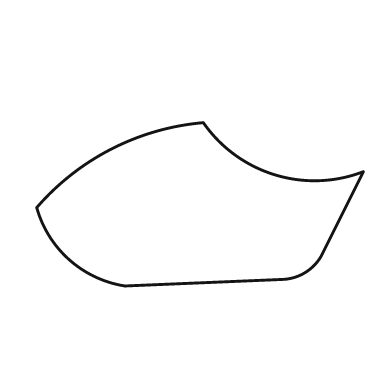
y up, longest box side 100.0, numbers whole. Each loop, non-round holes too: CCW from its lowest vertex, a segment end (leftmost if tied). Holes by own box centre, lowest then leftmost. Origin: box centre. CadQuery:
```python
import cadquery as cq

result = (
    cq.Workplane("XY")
    .moveTo(-23.0, -25.0)
    .lineTo(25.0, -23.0)
    .threePointArc((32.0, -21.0), (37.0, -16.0))
    .lineTo(50.0, 10.0)
    .threePointArc((23.0, 9.0), (1.0, 25.0))
    .threePointArc((-27.0, 17.0), (-50.0, -1.0))
    .threePointArc((-40.0, -17.0), (-23.0, -25.0))
    .close()
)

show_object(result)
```